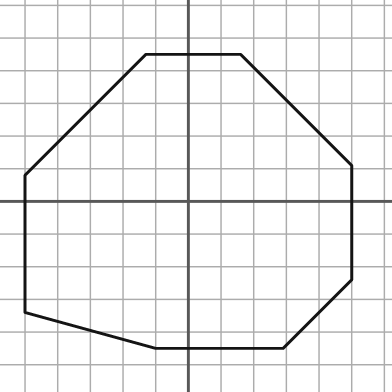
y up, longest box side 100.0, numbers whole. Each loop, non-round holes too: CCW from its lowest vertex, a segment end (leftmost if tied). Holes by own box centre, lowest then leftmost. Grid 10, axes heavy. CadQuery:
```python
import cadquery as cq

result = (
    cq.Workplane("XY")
    .moveTo(-10.0, -45.0)
    .lineTo(29.0, -45.0)
    .lineTo(50.0, -24.0)
    .lineTo(50.0, 11.0)
    .lineTo(16.0, 45.0)
    .lineTo(-13.0, 45.0)
    .lineTo(-50.0, 8.0)
    .lineTo(-50.0, -34.0)
    .close()
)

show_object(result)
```